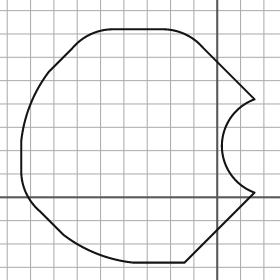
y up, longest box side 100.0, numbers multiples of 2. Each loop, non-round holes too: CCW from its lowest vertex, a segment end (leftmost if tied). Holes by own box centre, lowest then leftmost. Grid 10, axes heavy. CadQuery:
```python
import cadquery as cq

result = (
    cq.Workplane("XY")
    .moveTo(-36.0, -28.0)
    .lineTo(-14.0, -28.0)
    .lineTo(16.0, 2.0)
    .threePointArc((2.0, 22.0), (16.0, 42.0))
    .lineTo(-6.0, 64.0)
    .threePointArc((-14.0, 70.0), (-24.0, 72.0))
    .lineTo(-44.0, 72.0)
    .threePointArc((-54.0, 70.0), (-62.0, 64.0))
    .lineTo(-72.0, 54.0)
    .threePointArc((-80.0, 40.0), (-84.0, 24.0))
    .lineTo(-84.0, 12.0)
    .threePointArc((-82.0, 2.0), (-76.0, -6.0))
    .lineTo(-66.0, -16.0)
    .threePointArc((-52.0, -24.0), (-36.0, -28.0))
    .close()
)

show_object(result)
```